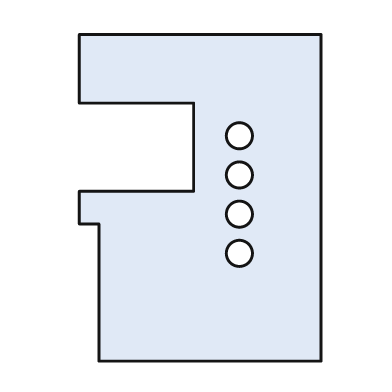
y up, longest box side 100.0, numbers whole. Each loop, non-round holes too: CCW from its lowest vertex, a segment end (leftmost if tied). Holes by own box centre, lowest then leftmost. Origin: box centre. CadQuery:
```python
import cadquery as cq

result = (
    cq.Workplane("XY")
    .moveTo(-31.0, -50.0)
    .lineTo(37.0, -50.0)
    .lineTo(37.0, 50.0)
    .lineTo(-37.0, 50.0)
    .lineTo(-37.0, 29.0)
    .lineTo(-2.0, 29.0)
    .lineTo(-2.0, 2.0)
    .lineTo(-37.0, 2.0)
    .lineTo(-37.0, -8.0)
    .lineTo(-31.0, -8.0)
    .close()
    .moveTo(12.0, -17.0)
    .circle(4.0)
    .moveTo(12.0, -5.0)
    .circle(4.0)
    .moveTo(12.0, 7.0)
    .circle(4.0)
    .moveTo(12.0, 19.0)
    .circle(4.0)
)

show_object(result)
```